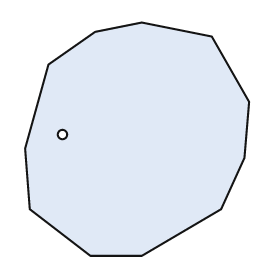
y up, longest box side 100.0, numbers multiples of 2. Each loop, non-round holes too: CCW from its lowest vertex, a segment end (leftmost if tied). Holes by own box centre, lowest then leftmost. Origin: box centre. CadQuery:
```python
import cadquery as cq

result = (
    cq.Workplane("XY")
    .moveTo(-20.0, -50.0)
    .lineTo(2.0, -50.0)
    .lineTo(36.0, -30.0)
    .lineTo(46.0, -8.0)
    .lineTo(48.0, 16.0)
    .lineTo(32.0, 44.0)
    .lineTo(2.0, 50.0)
    .lineTo(-18.0, 46.0)
    .lineTo(-38.0, 32.0)
    .lineTo(-48.0, -4.0)
    .lineTo(-46.0, -30.0)
    .close()
    .moveTo(-32.0, 2.0)
    .circle(2.0)
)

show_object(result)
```